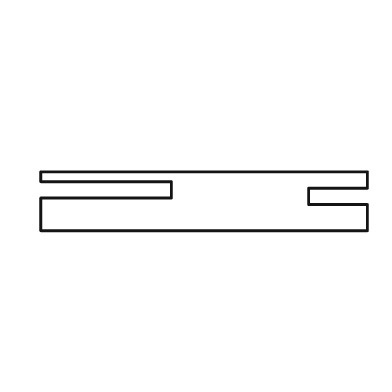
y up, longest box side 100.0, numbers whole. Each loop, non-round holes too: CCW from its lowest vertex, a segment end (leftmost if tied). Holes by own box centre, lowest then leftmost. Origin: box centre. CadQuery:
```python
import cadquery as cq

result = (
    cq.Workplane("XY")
    .moveTo(-50.0, -9.0)
    .lineTo(50.0, -9.0)
    .lineTo(50.0, -1.0)
    .lineTo(32.0, -1.0)
    .lineTo(32.0, 4.0)
    .lineTo(50.0, 4.0)
    .lineTo(50.0, 9.0)
    .lineTo(-50.0, 9.0)
    .lineTo(-50.0, 6.0)
    .lineTo(-10.0, 6.0)
    .lineTo(-10.0, 1.0)
    .lineTo(-50.0, 1.0)
    .close()
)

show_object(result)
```